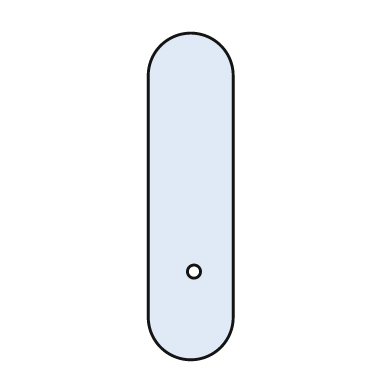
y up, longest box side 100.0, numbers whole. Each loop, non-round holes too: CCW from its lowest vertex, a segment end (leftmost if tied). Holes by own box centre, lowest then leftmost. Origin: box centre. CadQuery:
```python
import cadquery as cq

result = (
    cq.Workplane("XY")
    .moveTo(-13.0, -37.0)
    .threePointArc((0.0, -50.0), (13.0, -37.0))
    .lineTo(13.0, 37.0)
    .threePointArc((0.0, 50.0), (-13.0, 37.0))
    .close()
    .moveTo(1.0, -23.0)
    .circle(2.0)
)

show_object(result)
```